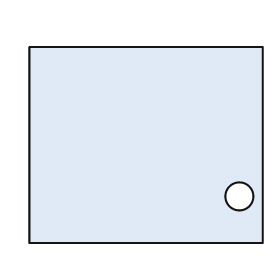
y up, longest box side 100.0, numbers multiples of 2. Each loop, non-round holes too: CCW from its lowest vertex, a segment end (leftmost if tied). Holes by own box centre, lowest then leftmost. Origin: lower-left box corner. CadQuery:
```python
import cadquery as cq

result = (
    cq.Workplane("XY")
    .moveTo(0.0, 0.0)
    .lineTo(100.0, 0.0)
    .lineTo(100.0, 84.0)
    .lineTo(0.0, 84.0)
    .close()
    .moveTo(90.0, 20.0)
    .circle(6.0)
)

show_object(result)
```